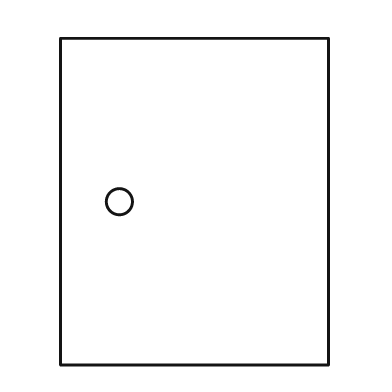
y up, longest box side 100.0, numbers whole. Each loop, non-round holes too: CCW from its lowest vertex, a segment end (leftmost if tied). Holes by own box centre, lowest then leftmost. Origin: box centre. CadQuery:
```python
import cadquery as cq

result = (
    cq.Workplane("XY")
    .moveTo(-41.0, -50.0)
    .lineTo(41.0, -50.0)
    .lineTo(41.0, 50.0)
    .lineTo(-41.0, 50.0)
    .close()
    .moveTo(-23.0, 0.0)
    .circle(4.0)
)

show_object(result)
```